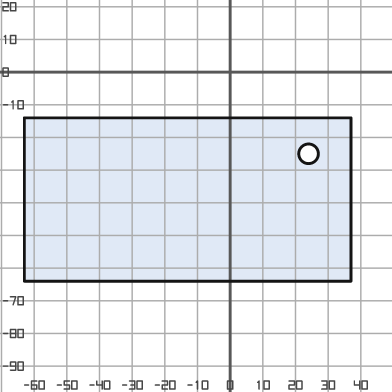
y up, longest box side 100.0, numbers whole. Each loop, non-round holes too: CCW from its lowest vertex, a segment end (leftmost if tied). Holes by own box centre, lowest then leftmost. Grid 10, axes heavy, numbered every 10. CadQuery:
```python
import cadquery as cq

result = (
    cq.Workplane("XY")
    .moveTo(-63.0, -64.0)
    .lineTo(37.0, -64.0)
    .lineTo(37.0, -14.0)
    .lineTo(-63.0, -14.0)
    .close()
    .moveTo(24.0, -25.0)
    .circle(3.0)
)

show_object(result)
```